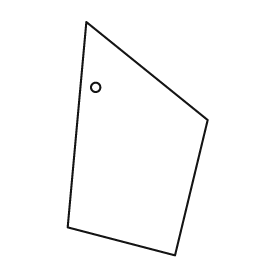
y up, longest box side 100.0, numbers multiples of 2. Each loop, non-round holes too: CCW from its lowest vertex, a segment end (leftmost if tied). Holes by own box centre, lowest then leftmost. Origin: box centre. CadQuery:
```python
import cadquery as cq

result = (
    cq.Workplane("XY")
    .moveTo(16.0, -50.0)
    .lineTo(30.0, 8.0)
    .lineTo(-22.0, 50.0)
    .lineTo(-30.0, -38.0)
    .close()
    .moveTo(-18.0, 22.0)
    .circle(2.0)
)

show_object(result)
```